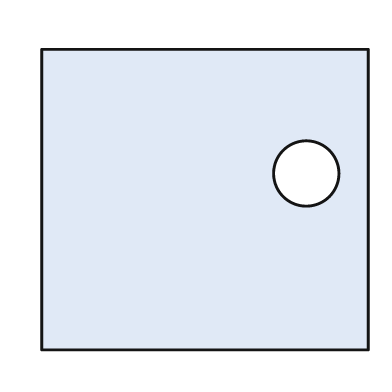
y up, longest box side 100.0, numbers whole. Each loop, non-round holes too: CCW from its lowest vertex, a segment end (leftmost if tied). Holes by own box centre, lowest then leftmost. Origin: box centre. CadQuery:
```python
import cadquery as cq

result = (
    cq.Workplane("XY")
    .moveTo(-50.0, -46.0)
    .lineTo(50.0, -46.0)
    .lineTo(50.0, 46.0)
    .lineTo(-50.0, 46.0)
    .close()
    .moveTo(31.0, 8.0)
    .circle(10.0)
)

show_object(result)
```